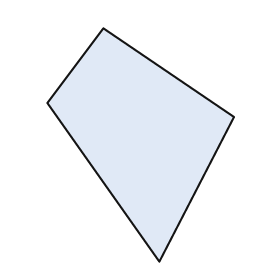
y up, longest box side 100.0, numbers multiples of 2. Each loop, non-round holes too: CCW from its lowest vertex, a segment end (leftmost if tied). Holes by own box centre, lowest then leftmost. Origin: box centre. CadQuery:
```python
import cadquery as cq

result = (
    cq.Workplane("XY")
    .moveTo(8.0, -50.0)
    .lineTo(40.0, 12.0)
    .lineTo(-16.0, 50.0)
    .lineTo(-40.0, 18.0)
    .close()
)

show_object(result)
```